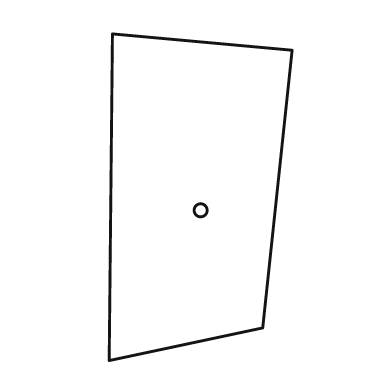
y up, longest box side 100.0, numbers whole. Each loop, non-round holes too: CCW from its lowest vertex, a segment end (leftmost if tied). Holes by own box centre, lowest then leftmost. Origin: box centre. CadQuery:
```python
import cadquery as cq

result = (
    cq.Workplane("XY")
    .moveTo(-28.0, -50.0)
    .lineTo(19.0, -40.0)
    .lineTo(28.0, 45.0)
    .lineTo(-27.0, 50.0)
    .close()
    .moveTo(0.0, -4.0)
    .circle(2.0)
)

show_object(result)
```